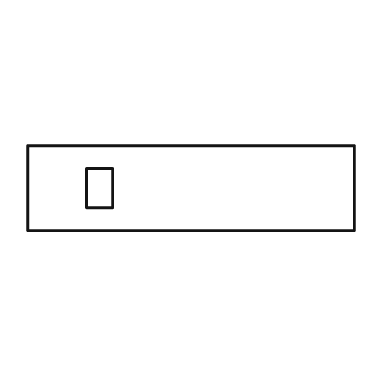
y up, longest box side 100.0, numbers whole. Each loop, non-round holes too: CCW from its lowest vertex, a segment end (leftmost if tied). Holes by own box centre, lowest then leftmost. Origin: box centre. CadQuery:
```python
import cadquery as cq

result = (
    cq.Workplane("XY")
    .moveTo(-50.0, -13.0)
    .lineTo(50.0, -13.0)
    .lineTo(50.0, 13.0)
    .lineTo(-50.0, 13.0)
    .close()
    .moveTo(-32.0, -6.0)
    .lineTo(-24.0, -6.0)
    .lineTo(-24.0, 6.0)
    .lineTo(-32.0, 6.0)
    .close()
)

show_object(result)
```